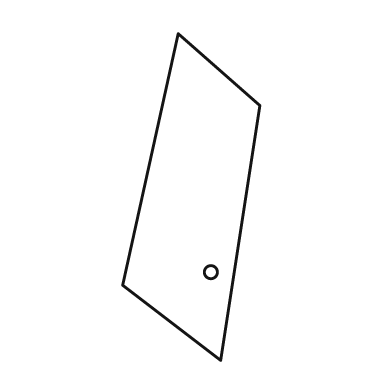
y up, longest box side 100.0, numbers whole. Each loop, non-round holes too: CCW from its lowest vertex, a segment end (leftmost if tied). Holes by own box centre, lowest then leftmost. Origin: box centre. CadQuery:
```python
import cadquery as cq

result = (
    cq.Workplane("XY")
    .moveTo(9.0, -50.0)
    .lineTo(21.0, 28.0)
    .lineTo(-4.0, 50.0)
    .lineTo(-21.0, -27.0)
    .close()
    .moveTo(6.0, -23.0)
    .circle(2.0)
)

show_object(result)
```